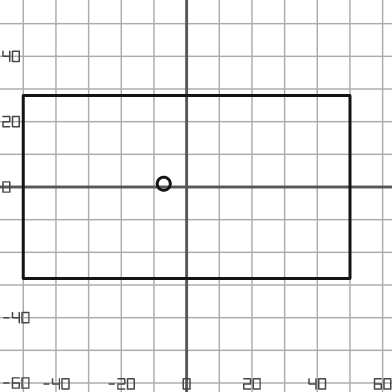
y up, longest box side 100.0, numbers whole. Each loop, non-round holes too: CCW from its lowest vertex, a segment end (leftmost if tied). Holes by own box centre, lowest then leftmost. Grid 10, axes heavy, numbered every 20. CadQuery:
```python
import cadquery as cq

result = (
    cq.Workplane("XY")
    .moveTo(-50.0, -28.0)
    .lineTo(50.0, -28.0)
    .lineTo(50.0, 28.0)
    .lineTo(-50.0, 28.0)
    .close()
    .moveTo(-7.0, 1.0)
    .circle(2.0)
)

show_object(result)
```